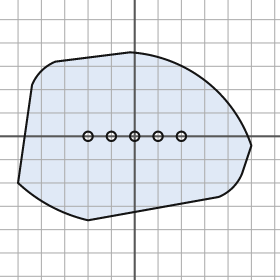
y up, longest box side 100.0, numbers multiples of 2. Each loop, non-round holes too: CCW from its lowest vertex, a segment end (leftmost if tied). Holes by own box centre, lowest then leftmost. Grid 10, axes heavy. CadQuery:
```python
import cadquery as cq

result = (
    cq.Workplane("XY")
    .moveTo(-20.0, -36.0)
    .lineTo(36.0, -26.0)
    .threePointArc((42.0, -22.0), (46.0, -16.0))
    .lineTo(50.0, -4.0)
    .threePointArc((30.0, 24.0), (-2.0, 36.0))
    .lineTo(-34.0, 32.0)
    .threePointArc((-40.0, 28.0), (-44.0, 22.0))
    .lineTo(-50.0, -20.0)
    .threePointArc((-36.0, -30.0), (-20.0, -36.0))
    .close()
    .moveTo(-20.0, 0.0)
    .circle(2.0)
    .moveTo(-10.0, 0.0)
    .circle(2.0)
    .moveTo(0.0, 0.0)
    .circle(2.0)
    .moveTo(10.0, 0.0)
    .circle(2.0)
    .moveTo(20.0, 0.0)
    .circle(2.0)
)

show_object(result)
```